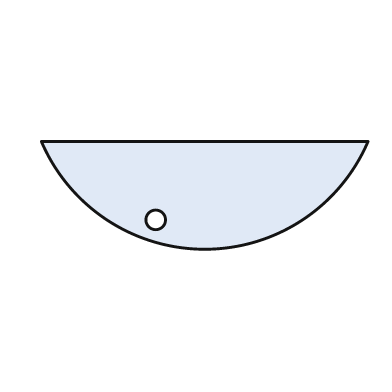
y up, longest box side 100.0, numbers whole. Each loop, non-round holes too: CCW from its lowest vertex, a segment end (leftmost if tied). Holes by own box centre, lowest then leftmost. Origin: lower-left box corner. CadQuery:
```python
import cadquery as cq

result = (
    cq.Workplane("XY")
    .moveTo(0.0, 33.0)
    .threePointArc((50.0, 0.0), (100.0, 33.0))
    .close()
    .moveTo(35.0, 9.0)
    .circle(3.0)
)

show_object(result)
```